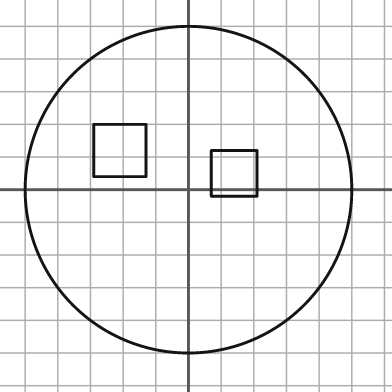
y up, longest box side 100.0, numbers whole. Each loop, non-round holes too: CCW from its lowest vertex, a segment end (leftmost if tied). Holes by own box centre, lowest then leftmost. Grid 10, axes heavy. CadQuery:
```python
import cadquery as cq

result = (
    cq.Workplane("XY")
    .moveTo(0.0, 0.0)
    .circle(50.0)
    .moveTo(7.0, -2.0)
    .lineTo(21.0, -2.0)
    .lineTo(21.0, 12.0)
    .lineTo(7.0, 12.0)
    .close()
    .moveTo(-29.0, 4.0)
    .lineTo(-13.0, 4.0)
    .lineTo(-13.0, 20.0)
    .lineTo(-29.0, 20.0)
    .close()
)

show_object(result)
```